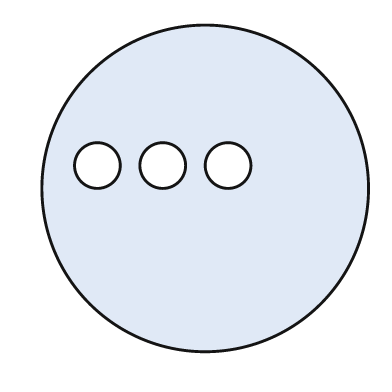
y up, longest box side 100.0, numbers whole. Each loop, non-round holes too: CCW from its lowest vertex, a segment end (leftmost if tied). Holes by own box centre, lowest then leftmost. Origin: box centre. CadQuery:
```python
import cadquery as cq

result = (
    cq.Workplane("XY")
    .moveTo(0.0, 0.0)
    .circle(50.0)
    .moveTo(-33.0, 7.0)
    .circle(7.0)
    .moveTo(-13.0, 7.0)
    .circle(7.0)
    .moveTo(7.0, 7.0)
    .circle(7.0)
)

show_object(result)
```